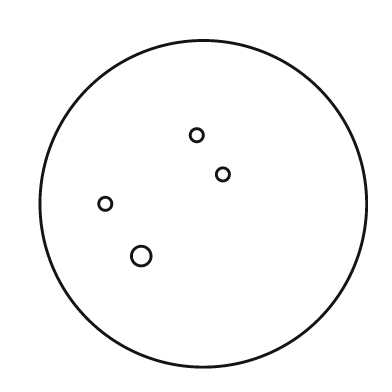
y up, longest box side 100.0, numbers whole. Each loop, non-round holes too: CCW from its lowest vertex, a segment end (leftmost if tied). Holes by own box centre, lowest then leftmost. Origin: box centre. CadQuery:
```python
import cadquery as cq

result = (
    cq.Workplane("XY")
    .moveTo(0.0, 0.0)
    .circle(50.0)
    .moveTo(-19.0, -16.0)
    .circle(3.0)
    .moveTo(-30.0, 0.0)
    .circle(2.0)
    .moveTo(6.0, 9.0)
    .circle(2.0)
    .moveTo(-2.0, 21.0)
    .circle(2.0)
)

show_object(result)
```